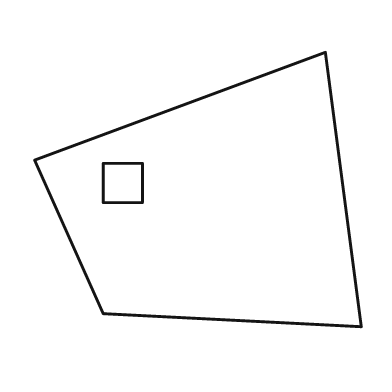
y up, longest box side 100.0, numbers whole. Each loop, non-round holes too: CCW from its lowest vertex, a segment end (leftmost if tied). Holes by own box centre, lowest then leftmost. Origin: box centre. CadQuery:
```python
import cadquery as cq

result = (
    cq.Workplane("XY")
    .moveTo(50.0, -42.0)
    .lineTo(39.0, 42.0)
    .lineTo(-50.0, 9.0)
    .lineTo(-29.0, -38.0)
    .close()
    .moveTo(-29.0, -4.0)
    .lineTo(-17.0, -4.0)
    .lineTo(-17.0, 8.0)
    .lineTo(-29.0, 8.0)
    .close()
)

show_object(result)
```